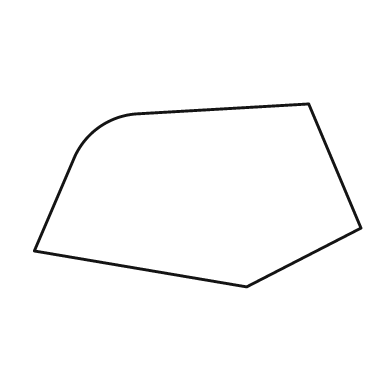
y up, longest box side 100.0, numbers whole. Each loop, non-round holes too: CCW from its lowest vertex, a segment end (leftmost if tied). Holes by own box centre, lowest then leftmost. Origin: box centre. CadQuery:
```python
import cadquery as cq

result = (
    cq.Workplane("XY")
    .moveTo(15.0, -28.0)
    .lineTo(50.0, -10.0)
    .lineTo(34.0, 28.0)
    .lineTo(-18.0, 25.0)
    .threePointArc((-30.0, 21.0), (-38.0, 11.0))
    .lineTo(-50.0, -17.0)
    .close()
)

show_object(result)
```